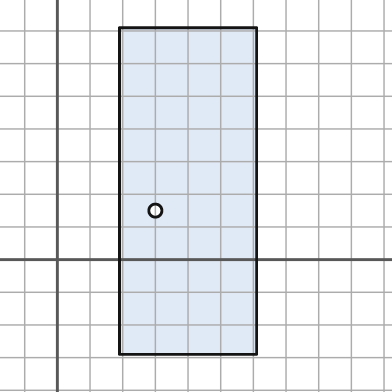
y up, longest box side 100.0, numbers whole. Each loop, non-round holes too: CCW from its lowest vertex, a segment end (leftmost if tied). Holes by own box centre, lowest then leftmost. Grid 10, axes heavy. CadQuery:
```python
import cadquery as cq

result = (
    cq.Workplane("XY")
    .moveTo(19.0, -29.0)
    .lineTo(61.0, -29.0)
    .lineTo(61.0, 71.0)
    .lineTo(19.0, 71.0)
    .close()
    .moveTo(30.0, 15.0)
    .circle(2.0)
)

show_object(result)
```